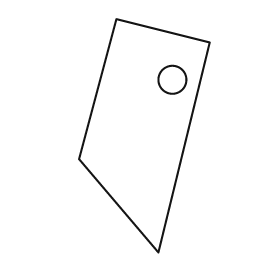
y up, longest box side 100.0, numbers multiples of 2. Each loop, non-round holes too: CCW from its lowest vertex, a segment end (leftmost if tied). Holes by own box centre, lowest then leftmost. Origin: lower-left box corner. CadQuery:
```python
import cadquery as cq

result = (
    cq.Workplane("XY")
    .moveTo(34.0, 0.0)
    .lineTo(56.0, 90.0)
    .lineTo(16.0, 100.0)
    .lineTo(0.0, 40.0)
    .close()
    .moveTo(40.0, 74.0)
    .circle(6.0)
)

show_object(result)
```